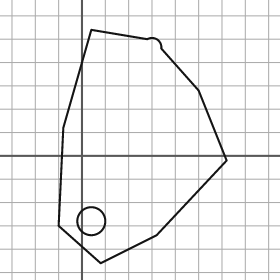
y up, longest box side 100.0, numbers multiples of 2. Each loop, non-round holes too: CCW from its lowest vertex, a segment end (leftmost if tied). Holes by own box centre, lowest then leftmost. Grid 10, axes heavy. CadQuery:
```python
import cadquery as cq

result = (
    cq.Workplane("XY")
    .moveTo(8.0, -46.0)
    .lineTo(32.0, -34.0)
    .lineTo(62.0, -2.0)
    .lineTo(50.0, 28.0)
    .lineTo(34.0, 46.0)
    .threePointArc((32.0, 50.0), (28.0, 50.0))
    .lineTo(4.0, 54.0)
    .lineTo(-8.0, 12.0)
    .lineTo(-10.0, -30.0)
    .close()
    .moveTo(4.0, -28.0)
    .circle(6.0)
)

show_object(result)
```